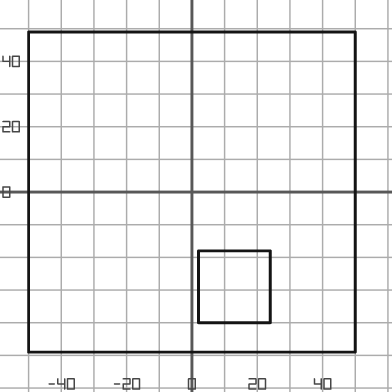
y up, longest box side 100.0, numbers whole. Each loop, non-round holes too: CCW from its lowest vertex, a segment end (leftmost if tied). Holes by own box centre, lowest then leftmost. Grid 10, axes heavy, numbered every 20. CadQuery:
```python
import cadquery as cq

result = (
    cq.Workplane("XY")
    .moveTo(-50.0, -49.0)
    .lineTo(50.0, -49.0)
    .lineTo(50.0, 49.0)
    .lineTo(-50.0, 49.0)
    .close()
    .moveTo(2.0, -40.0)
    .lineTo(24.0, -40.0)
    .lineTo(24.0, -18.0)
    .lineTo(2.0, -18.0)
    .close()
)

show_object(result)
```